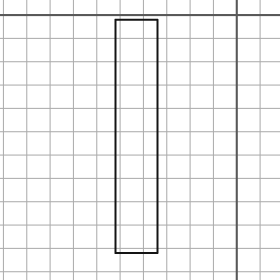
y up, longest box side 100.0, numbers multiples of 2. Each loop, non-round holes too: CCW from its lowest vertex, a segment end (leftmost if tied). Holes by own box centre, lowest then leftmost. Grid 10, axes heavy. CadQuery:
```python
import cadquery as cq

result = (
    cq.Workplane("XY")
    .moveTo(-52.0, -102.0)
    .lineTo(-34.0, -102.0)
    .lineTo(-34.0, -2.0)
    .lineTo(-52.0, -2.0)
    .close()
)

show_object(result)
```